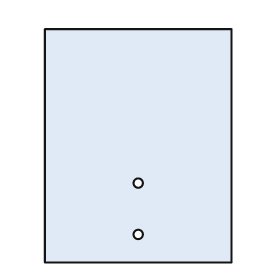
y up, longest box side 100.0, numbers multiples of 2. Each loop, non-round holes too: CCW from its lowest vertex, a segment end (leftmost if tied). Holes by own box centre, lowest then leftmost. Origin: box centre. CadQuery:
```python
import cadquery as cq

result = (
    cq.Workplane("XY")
    .moveTo(-40.0, -50.0)
    .lineTo(40.0, -50.0)
    .lineTo(40.0, 50.0)
    .lineTo(-40.0, 50.0)
    .close()
    .moveTo(0.0, -38.0)
    .circle(2.0)
    .moveTo(0.0, -16.0)
    .circle(2.0)
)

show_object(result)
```